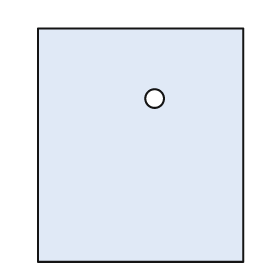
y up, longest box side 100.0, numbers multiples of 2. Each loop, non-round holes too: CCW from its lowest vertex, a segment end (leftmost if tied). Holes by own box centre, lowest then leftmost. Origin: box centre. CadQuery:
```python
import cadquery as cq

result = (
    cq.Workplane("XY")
    .moveTo(-44.0, -50.0)
    .lineTo(44.0, -50.0)
    .lineTo(44.0, 50.0)
    .lineTo(-44.0, 50.0)
    .close()
    .moveTo(6.0, 20.0)
    .circle(4.0)
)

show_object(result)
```